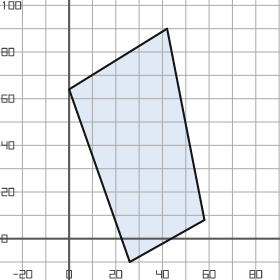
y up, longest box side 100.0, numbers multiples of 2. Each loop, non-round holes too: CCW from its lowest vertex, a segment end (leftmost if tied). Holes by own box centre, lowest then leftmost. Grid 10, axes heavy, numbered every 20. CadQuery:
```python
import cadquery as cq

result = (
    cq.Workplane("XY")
    .moveTo(26.0, -10.0)
    .lineTo(58.0, 8.0)
    .lineTo(42.0, 90.0)
    .lineTo(0.0, 64.0)
    .close()
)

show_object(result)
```